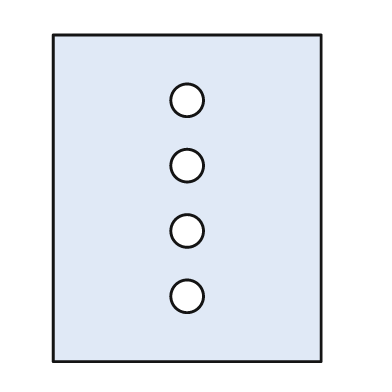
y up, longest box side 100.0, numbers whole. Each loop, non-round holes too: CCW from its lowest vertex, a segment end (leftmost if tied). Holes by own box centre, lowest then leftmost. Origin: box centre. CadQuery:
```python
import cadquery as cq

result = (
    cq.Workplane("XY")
    .moveTo(-41.0, -50.0)
    .lineTo(41.0, -50.0)
    .lineTo(41.0, 50.0)
    .lineTo(-41.0, 50.0)
    .close()
    .moveTo(0.0, -30.0)
    .circle(5.0)
    .moveTo(0.0, -10.0)
    .circle(5.0)
    .moveTo(0.0, 10.0)
    .circle(5.0)
    .moveTo(0.0, 30.0)
    .circle(5.0)
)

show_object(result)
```